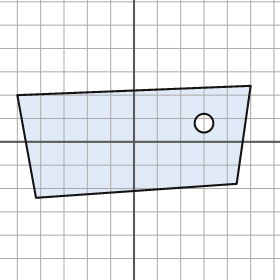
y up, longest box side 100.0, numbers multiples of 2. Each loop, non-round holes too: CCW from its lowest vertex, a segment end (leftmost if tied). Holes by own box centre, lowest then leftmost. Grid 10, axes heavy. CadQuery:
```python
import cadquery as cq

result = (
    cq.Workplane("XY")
    .moveTo(-42.0, -24.0)
    .lineTo(44.0, -18.0)
    .lineTo(50.0, 24.0)
    .lineTo(-50.0, 20.0)
    .close()
    .moveTo(30.0, 8.0)
    .circle(4.0)
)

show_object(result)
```